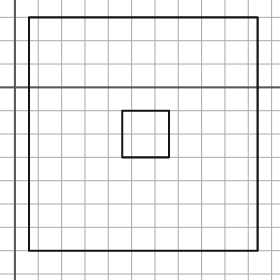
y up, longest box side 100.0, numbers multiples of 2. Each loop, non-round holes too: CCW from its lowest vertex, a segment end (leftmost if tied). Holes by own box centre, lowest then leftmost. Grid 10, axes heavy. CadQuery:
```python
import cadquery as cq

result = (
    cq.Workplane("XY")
    .moveTo(6.0, -70.0)
    .lineTo(104.0, -70.0)
    .lineTo(104.0, 30.0)
    .lineTo(6.0, 30.0)
    .close()
    .moveTo(46.0, -30.0)
    .lineTo(66.0, -30.0)
    .lineTo(66.0, -10.0)
    .lineTo(46.0, -10.0)
    .close()
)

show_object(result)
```